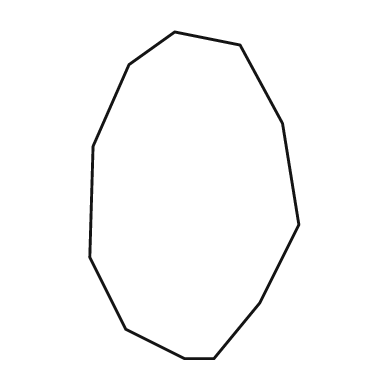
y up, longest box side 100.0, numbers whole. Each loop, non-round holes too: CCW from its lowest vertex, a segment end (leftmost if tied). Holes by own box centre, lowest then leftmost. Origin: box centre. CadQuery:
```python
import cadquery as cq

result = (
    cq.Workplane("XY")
    .moveTo(-3.0, -50.0)
    .lineTo(6.0, -50.0)
    .lineTo(20.0, -33.0)
    .lineTo(32.0, -9.0)
    .lineTo(27.0, 22.0)
    .lineTo(14.0, 46.0)
    .lineTo(-6.0, 50.0)
    .lineTo(-20.0, 40.0)
    .lineTo(-31.0, 15.0)
    .lineTo(-32.0, -19.0)
    .lineTo(-21.0, -41.0)
    .close()
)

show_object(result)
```